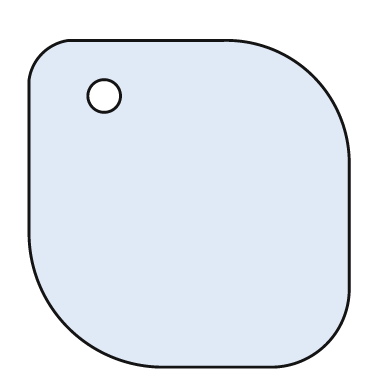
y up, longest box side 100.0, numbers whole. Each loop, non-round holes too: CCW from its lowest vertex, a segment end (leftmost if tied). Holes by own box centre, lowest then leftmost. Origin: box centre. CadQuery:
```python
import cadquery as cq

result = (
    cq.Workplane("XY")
    .moveTo(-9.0, -50.0)
    .lineTo(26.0, -50.0)
    .threePointArc((42.0, -43.0), (49.0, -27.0))
    .lineTo(49.0, 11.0)
    .threePointArc((38.0, 39.0), (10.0, 50.0))
    .lineTo(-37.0, 50.0)
    .threePointArc((-45.0, 46.0), (-49.0, 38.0))
    .lineTo(-49.0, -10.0)
    .threePointArc((-37.0, -38.0), (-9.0, -50.0))
    .close()
    .moveTo(-26.0, 33.0)
    .circle(5.0)
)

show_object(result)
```